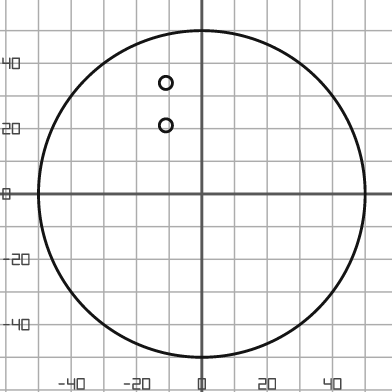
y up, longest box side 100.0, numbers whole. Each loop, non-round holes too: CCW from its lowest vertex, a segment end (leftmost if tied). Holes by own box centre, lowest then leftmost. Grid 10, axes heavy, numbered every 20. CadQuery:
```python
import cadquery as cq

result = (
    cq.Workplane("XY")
    .moveTo(0.0, 0.0)
    .circle(50.0)
    .moveTo(-11.0, 21.0)
    .circle(2.0)
    .moveTo(-11.0, 34.0)
    .circle(2.0)
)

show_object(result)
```